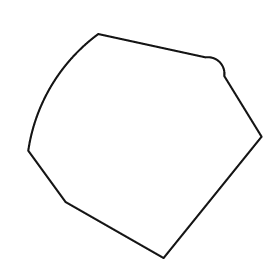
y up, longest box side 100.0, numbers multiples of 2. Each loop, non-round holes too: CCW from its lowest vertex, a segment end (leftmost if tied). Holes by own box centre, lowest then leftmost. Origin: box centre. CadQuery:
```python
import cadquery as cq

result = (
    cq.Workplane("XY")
    .moveTo(8.0, -48.0)
    .lineTo(50.0, 4.0)
    .lineTo(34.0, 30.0)
    .threePointArc((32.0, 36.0), (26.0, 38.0))
    .lineTo(-20.0, 48.0)
    .threePointArc((-40.0, 26.0), (-50.0, -2.0))
    .lineTo(-34.0, -24.0)
    .close()
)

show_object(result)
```